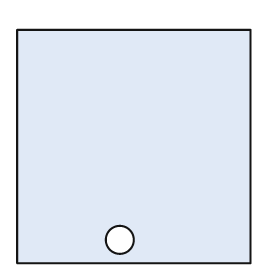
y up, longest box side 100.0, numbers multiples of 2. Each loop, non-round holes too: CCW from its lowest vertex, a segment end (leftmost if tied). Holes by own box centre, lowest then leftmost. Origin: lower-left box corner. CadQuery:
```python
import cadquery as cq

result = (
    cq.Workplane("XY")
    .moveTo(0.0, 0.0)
    .lineTo(100.0, 0.0)
    .lineTo(100.0, 100.0)
    .lineTo(0.0, 100.0)
    .close()
    .moveTo(44.0, 10.0)
    .circle(6.0)
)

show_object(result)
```